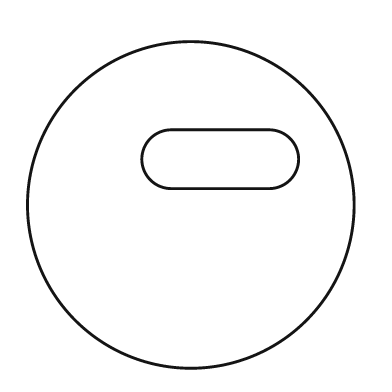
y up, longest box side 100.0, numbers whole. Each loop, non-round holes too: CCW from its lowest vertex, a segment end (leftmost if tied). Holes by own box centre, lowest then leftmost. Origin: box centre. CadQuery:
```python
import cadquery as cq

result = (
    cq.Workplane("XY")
    .moveTo(0.0, 0.0)
    .circle(50.0)
    .moveTo(-6.0, 5.0)
    .lineTo(24.0, 5.0)
    .threePointArc((33.0, 14.0), (24.0, 23.0))
    .lineTo(-6.0, 23.0)
    .threePointArc((-15.0, 14.0), (-6.0, 5.0))
    .close()
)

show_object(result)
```